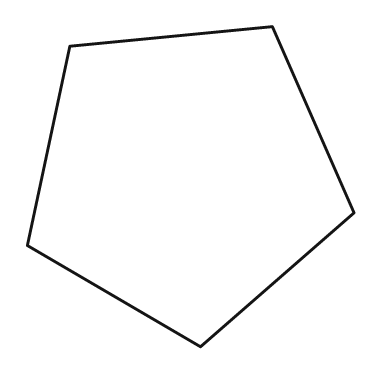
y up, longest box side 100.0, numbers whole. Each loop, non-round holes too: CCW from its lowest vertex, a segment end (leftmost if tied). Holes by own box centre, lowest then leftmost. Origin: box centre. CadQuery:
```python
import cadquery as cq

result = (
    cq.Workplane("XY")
    .moveTo(3.0, -49.0)
    .lineTo(50.0, -8.0)
    .lineTo(25.0, 49.0)
    .lineTo(-37.0, 43.0)
    .lineTo(-50.0, -18.0)
    .close()
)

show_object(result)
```